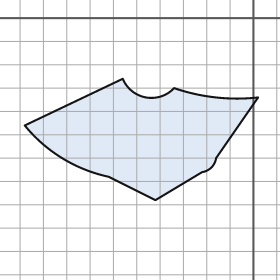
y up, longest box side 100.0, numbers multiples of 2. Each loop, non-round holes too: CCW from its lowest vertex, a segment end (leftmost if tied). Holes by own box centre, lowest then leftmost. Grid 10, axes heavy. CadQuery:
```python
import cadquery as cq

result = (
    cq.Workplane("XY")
    .moveTo(-42.0, -78.0)
    .lineTo(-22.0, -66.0)
    .threePointArc((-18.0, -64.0), (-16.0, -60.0))
    .lineTo(2.0, -34.0)
    .threePointArc((-16.0, -34.0), (-34.0, -30.0))
    .threePointArc((-46.0, -34.0), (-56.0, -26.0))
    .lineTo(-98.0, -46.0)
    .threePointArc((-82.0, -60.0), (-62.0, -68.0))
    .close()
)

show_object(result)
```